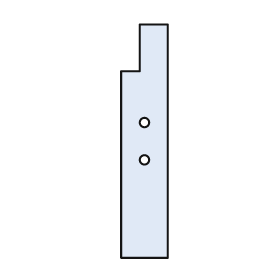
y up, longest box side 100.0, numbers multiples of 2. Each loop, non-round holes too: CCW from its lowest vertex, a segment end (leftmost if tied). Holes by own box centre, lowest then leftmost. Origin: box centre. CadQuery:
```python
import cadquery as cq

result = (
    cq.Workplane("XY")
    .moveTo(-10.0, -50.0)
    .lineTo(10.0, -50.0)
    .lineTo(10.0, 50.0)
    .lineTo(-2.0, 50.0)
    .lineTo(-2.0, 30.0)
    .lineTo(-10.0, 30.0)
    .close()
    .moveTo(0.0, -8.0)
    .circle(2.0)
    .moveTo(0.0, 8.0)
    .circle(2.0)
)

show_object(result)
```